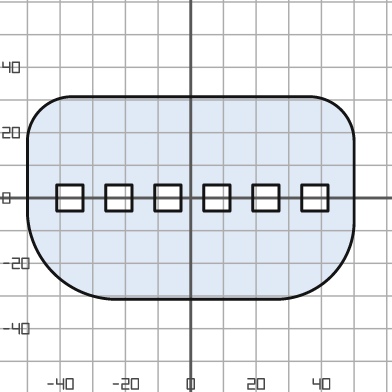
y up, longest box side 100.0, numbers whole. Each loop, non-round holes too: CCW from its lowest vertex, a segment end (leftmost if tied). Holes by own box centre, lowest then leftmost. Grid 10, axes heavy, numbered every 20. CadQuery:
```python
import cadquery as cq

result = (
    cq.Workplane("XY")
    .moveTo(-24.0, -31.0)
    .lineTo(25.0, -31.0)
    .threePointArc((43.0, -24.0), (50.0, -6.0))
    .lineTo(50.0, 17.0)
    .threePointArc((46.0, 27.0), (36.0, 31.0))
    .lineTo(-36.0, 31.0)
    .threePointArc((-46.0, 27.0), (-50.0, 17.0))
    .lineTo(-50.0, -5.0)
    .threePointArc((-42.0, -23.0), (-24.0, -31.0))
    .close()
    .moveTo(-41.0, -4.0)
    .lineTo(-33.0, -4.0)
    .lineTo(-33.0, 4.0)
    .lineTo(-41.0, 4.0)
    .close()
    .moveTo(-26.0, -4.0)
    .lineTo(-18.0, -4.0)
    .lineTo(-18.0, 4.0)
    .lineTo(-26.0, 4.0)
    .close()
    .moveTo(-11.0, -4.0)
    .lineTo(-3.0, -4.0)
    .lineTo(-3.0, 4.0)
    .lineTo(-11.0, 4.0)
    .close()
    .moveTo(4.0, -4.0)
    .lineTo(12.0, -4.0)
    .lineTo(12.0, 4.0)
    .lineTo(4.0, 4.0)
    .close()
    .moveTo(19.0, -4.0)
    .lineTo(27.0, -4.0)
    .lineTo(27.0, 4.0)
    .lineTo(19.0, 4.0)
    .close()
    .moveTo(34.0, -4.0)
    .lineTo(42.0, -4.0)
    .lineTo(42.0, 4.0)
    .lineTo(34.0, 4.0)
    .close()
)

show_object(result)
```